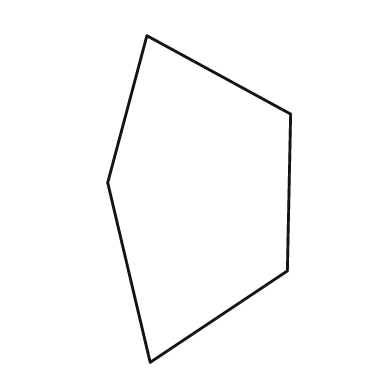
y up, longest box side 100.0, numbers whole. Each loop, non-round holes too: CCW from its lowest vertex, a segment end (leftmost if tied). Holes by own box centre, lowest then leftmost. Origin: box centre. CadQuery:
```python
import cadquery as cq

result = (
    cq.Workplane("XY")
    .moveTo(-15.0, -50.0)
    .lineTo(27.0, -22.0)
    .lineTo(28.0, 26.0)
    .lineTo(-16.0, 50.0)
    .lineTo(-28.0, 5.0)
    .close()
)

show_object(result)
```